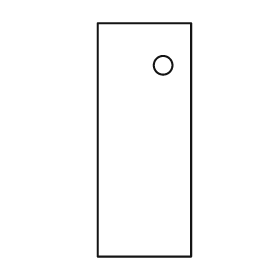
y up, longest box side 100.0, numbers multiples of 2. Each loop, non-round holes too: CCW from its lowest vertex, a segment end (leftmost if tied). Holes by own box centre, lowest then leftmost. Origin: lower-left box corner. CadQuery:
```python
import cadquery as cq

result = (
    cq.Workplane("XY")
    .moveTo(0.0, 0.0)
    .lineTo(40.0, 0.0)
    .lineTo(40.0, 100.0)
    .lineTo(0.0, 100.0)
    .close()
    .moveTo(28.0, 82.0)
    .circle(4.0)
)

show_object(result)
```